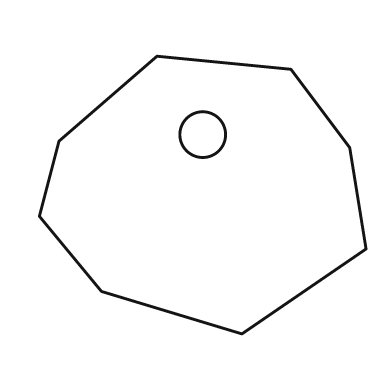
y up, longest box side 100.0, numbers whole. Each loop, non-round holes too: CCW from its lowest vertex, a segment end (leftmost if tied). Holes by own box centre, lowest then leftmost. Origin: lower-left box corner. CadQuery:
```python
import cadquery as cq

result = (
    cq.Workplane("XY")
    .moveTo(62.0, 0.0)
    .lineTo(100.0, 26.0)
    .lineTo(95.0, 57.0)
    .lineTo(77.0, 81.0)
    .lineTo(36.0, 85.0)
    .lineTo(6.0, 59.0)
    .lineTo(0.0, 36.0)
    .lineTo(19.0, 13.0)
    .close()
    .moveTo(50.0, 61.0)
    .circle(7.0)
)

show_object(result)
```